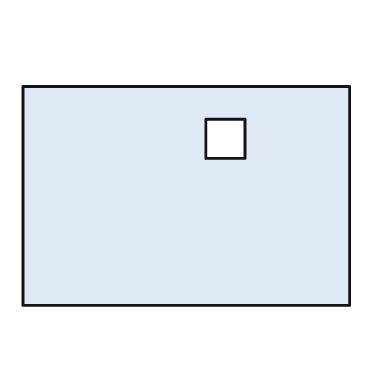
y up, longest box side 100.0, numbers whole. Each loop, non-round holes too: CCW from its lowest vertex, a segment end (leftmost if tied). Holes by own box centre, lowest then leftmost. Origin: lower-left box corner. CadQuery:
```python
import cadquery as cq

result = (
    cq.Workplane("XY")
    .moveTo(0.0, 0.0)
    .lineTo(100.0, 0.0)
    .lineTo(100.0, 67.0)
    .lineTo(0.0, 67.0)
    .close()
    .moveTo(56.0, 45.0)
    .lineTo(68.0, 45.0)
    .lineTo(68.0, 57.0)
    .lineTo(56.0, 57.0)
    .close()
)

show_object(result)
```